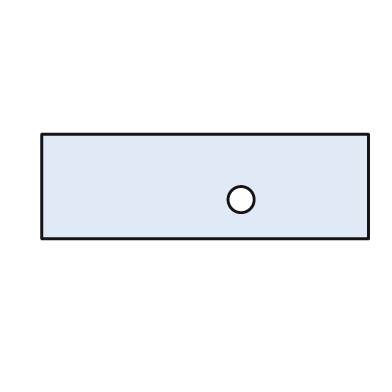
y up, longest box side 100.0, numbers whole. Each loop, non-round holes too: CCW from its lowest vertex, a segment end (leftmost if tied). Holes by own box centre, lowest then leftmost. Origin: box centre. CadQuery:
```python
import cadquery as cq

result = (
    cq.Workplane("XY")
    .moveTo(-50.0, -16.0)
    .lineTo(50.0, -16.0)
    .lineTo(50.0, 16.0)
    .lineTo(-50.0, 16.0)
    .close()
    .moveTo(11.0, -4.0)
    .circle(4.0)
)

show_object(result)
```